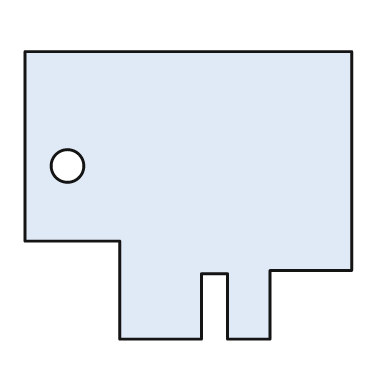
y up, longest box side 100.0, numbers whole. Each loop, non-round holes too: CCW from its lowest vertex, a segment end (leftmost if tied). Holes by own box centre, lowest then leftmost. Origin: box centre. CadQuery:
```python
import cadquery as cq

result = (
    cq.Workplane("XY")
    .moveTo(-21.0, -44.0)
    .lineTo(4.0, -44.0)
    .lineTo(4.0, -24.0)
    .lineTo(12.0, -24.0)
    .lineTo(12.0, -44.0)
    .lineTo(25.0, -44.0)
    .lineTo(25.0, -23.0)
    .lineTo(50.0, -23.0)
    .lineTo(50.0, 44.0)
    .lineTo(-50.0, 44.0)
    .lineTo(-50.0, -14.0)
    .lineTo(-21.0, -14.0)
    .close()
    .moveTo(-37.0, 9.0)
    .circle(5.0)
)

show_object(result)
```